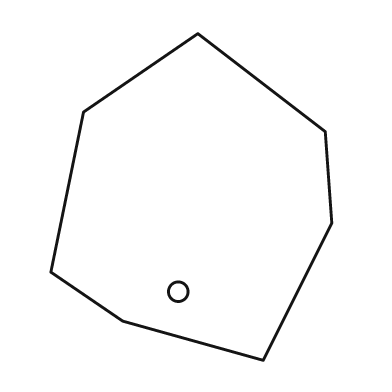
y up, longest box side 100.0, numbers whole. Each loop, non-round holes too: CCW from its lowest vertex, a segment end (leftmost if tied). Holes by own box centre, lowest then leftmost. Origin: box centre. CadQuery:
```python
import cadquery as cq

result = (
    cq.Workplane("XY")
    .moveTo(22.0, -50.0)
    .lineTo(43.0, -8.0)
    .lineTo(41.0, 20.0)
    .lineTo(2.0, 50.0)
    .lineTo(-33.0, 26.0)
    .lineTo(-43.0, -23.0)
    .lineTo(-21.0, -38.0)
    .close()
    .moveTo(-4.0, -29.0)
    .circle(3.0)
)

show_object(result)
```